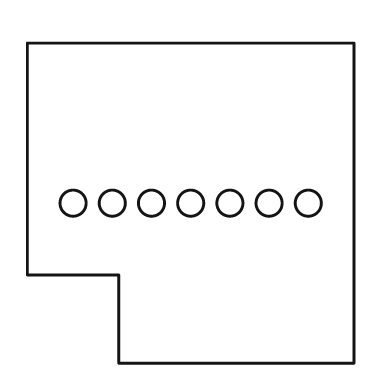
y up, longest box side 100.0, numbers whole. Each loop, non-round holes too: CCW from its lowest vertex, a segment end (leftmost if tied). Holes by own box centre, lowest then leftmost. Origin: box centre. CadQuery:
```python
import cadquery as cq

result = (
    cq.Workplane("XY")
    .moveTo(-22.0, -49.0)
    .lineTo(50.0, -49.0)
    .lineTo(50.0, 49.0)
    .lineTo(-50.0, 49.0)
    .lineTo(-50.0, -22.0)
    .lineTo(-22.0, -22.0)
    .close()
    .moveTo(-36.0, 0.0)
    .circle(4.0)
    .moveTo(-24.0, 0.0)
    .circle(4.0)
    .moveTo(-12.0, 0.0)
    .circle(4.0)
    .moveTo(0.0, 0.0)
    .circle(4.0)
    .moveTo(12.0, 0.0)
    .circle(4.0)
    .moveTo(24.0, 0.0)
    .circle(4.0)
    .moveTo(36.0, 0.0)
    .circle(4.0)
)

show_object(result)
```